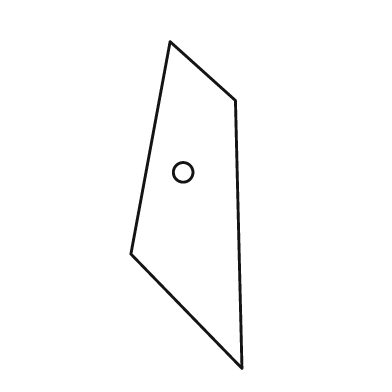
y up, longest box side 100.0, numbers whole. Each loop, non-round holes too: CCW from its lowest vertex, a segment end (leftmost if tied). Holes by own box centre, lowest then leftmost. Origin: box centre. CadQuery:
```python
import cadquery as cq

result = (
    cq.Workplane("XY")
    .moveTo(17.0, -50.0)
    .lineTo(15.0, 32.0)
    .lineTo(-5.0, 50.0)
    .lineTo(-17.0, -15.0)
    .close()
    .moveTo(-1.0, 10.0)
    .circle(3.0)
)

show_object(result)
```